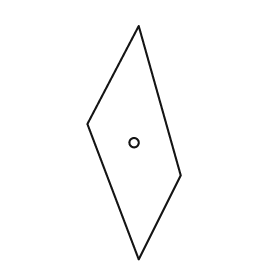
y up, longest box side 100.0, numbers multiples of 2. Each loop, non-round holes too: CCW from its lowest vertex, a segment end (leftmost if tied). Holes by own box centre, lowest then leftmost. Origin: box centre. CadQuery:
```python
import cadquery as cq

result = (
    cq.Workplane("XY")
    .moveTo(2.0, -50.0)
    .lineTo(20.0, -14.0)
    .lineTo(2.0, 50.0)
    .lineTo(-20.0, 8.0)
    .close()
    .moveTo(0.0, 0.0)
    .circle(2.0)
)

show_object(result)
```